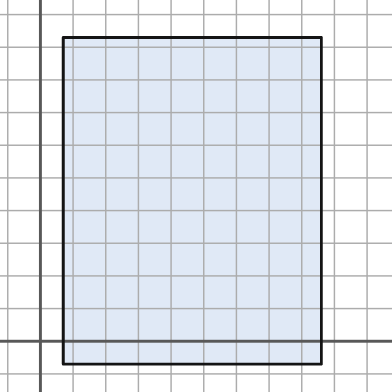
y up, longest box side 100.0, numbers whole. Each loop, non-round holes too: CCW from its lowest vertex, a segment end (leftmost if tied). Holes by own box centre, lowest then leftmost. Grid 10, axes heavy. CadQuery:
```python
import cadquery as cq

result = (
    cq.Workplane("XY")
    .moveTo(7.0, -7.0)
    .lineTo(86.0, -7.0)
    .lineTo(86.0, 93.0)
    .lineTo(7.0, 93.0)
    .close()
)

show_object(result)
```